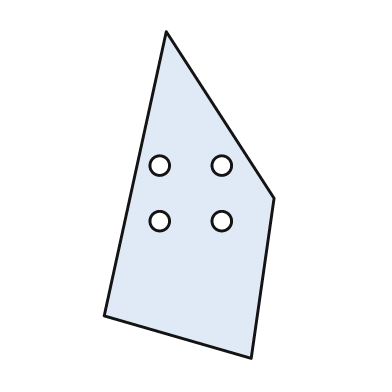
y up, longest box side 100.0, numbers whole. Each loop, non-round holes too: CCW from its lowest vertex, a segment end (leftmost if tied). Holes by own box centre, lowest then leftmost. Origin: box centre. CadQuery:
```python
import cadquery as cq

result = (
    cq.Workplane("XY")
    .moveTo(19.0, -50.0)
    .lineTo(26.0, -1.0)
    .lineTo(-7.0, 50.0)
    .lineTo(-26.0, -37.0)
    .close()
    .moveTo(-9.0, -8.0)
    .circle(3.0)
    .moveTo(10.0, -8.0)
    .circle(3.0)
    .moveTo(-9.0, 9.0)
    .circle(3.0)
    .moveTo(10.0, 9.0)
    .circle(3.0)
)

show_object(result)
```